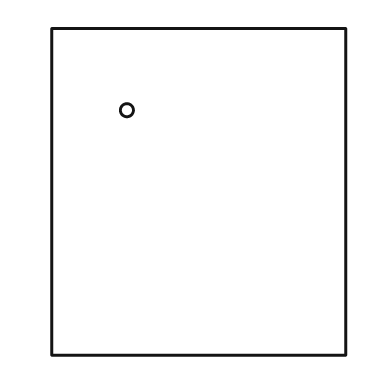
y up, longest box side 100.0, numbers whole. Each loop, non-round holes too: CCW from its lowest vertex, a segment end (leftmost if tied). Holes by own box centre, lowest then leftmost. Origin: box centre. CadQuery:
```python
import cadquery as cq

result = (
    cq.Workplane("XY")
    .moveTo(-45.0, -50.0)
    .lineTo(45.0, -50.0)
    .lineTo(45.0, 50.0)
    .lineTo(-45.0, 50.0)
    .close()
    .moveTo(-22.0, 25.0)
    .circle(2.0)
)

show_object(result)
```